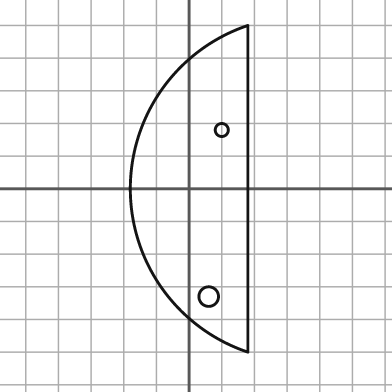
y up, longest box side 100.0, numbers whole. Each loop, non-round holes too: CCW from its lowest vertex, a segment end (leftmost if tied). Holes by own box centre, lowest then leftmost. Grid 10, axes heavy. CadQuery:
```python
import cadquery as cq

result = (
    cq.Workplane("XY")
    .moveTo(18.0, -50.0)
    .lineTo(18.0, 50.0)
    .threePointArc((-18.0, 0.0), (18.0, -50.0))
    .close()
    .moveTo(6.0, -33.0)
    .circle(3.0)
    .moveTo(10.0, 18.0)
    .circle(2.0)
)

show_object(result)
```